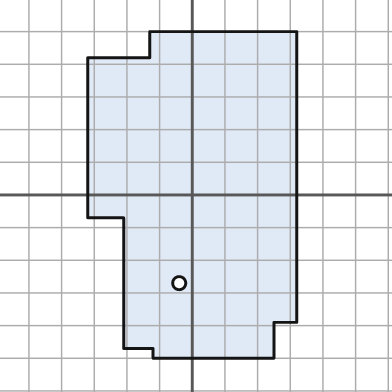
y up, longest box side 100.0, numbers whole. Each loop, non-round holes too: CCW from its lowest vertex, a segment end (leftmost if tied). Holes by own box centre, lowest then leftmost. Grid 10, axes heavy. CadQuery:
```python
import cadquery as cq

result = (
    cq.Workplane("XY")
    .moveTo(-12.0, -50.0)
    .lineTo(25.0, -50.0)
    .lineTo(25.0, -39.0)
    .lineTo(32.0, -39.0)
    .lineTo(32.0, 50.0)
    .lineTo(-13.0, 50.0)
    .lineTo(-13.0, 42.0)
    .lineTo(-32.0, 42.0)
    .lineTo(-32.0, -7.0)
    .lineTo(-21.0, -7.0)
    .lineTo(-21.0, -47.0)
    .lineTo(-12.0, -47.0)
    .close()
    .moveTo(-4.0, -27.0)
    .circle(2.0)
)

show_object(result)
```